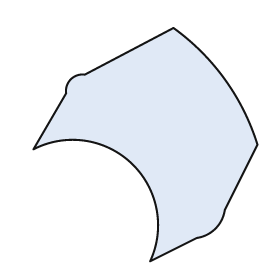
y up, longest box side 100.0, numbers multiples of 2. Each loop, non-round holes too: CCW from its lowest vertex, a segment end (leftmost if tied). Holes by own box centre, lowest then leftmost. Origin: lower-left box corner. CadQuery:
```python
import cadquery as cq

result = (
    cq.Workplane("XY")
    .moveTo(50.0, 0.0)
    .lineTo(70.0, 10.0)
    .threePointArc((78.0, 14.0), (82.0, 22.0))
    .lineTo(96.0, 50.0)
    .threePointArc((82.0, 78.0), (60.0, 100.0))
    .lineTo(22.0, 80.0)
    .threePointArc((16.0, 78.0), (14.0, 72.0))
    .lineTo(0.0, 48.0)
    .threePointArc((42.0, 42.0), (50.0, 0.0))
    .close()
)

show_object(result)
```